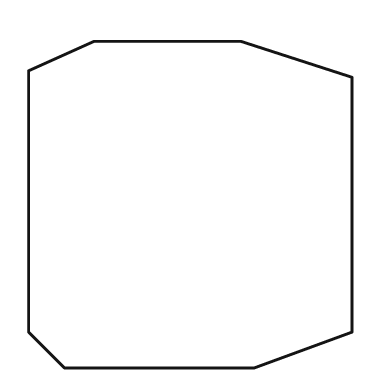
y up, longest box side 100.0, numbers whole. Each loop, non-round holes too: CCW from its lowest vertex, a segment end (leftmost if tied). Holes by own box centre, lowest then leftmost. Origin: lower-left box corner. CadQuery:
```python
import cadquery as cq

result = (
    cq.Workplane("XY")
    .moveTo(11.0, 0.0)
    .lineTo(69.0, 0.0)
    .lineTo(99.0, 11.0)
    .lineTo(99.0, 89.0)
    .lineTo(65.0, 100.0)
    .lineTo(20.0, 100.0)
    .lineTo(0.0, 91.0)
    .lineTo(0.0, 11.0)
    .close()
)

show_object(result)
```